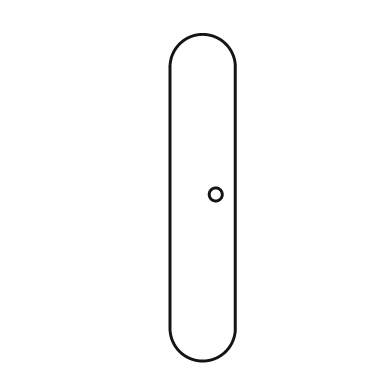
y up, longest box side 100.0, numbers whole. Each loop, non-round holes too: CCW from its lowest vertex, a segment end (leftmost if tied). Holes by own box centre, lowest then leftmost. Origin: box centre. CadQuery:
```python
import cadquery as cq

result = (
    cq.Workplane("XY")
    .moveTo(-10.0, -40.0)
    .threePointArc((0.0, -50.0), (10.0, -40.0))
    .lineTo(10.0, 40.0)
    .threePointArc((0.0, 50.0), (-10.0, 40.0))
    .close()
    .moveTo(4.0, 1.0)
    .circle(2.0)
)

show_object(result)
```